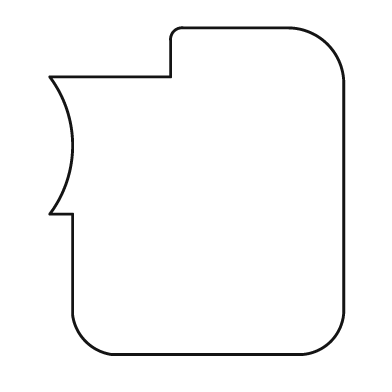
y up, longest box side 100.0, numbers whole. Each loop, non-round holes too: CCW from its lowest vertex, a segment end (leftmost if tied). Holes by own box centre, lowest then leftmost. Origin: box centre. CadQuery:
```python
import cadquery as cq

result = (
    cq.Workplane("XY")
    .moveTo(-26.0, -50.0)
    .lineTo(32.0, -50.0)
    .threePointArc((41.0, -46.0), (45.0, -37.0))
    .lineTo(45.0, 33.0)
    .threePointArc((40.0, 45.0), (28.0, 50.0))
    .lineTo(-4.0, 50.0)
    .threePointArc((-7.0, 49.0), (-8.0, 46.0))
    .lineTo(-8.0, 35.0)
    .lineTo(-45.0, 35.0)
    .threePointArc((-38.0, 14.0), (-45.0, -7.0))
    .lineTo(-38.0, -7.0)
    .lineTo(-38.0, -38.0)
    .threePointArc((-34.0, -46.0), (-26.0, -50.0))
    .close()
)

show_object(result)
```